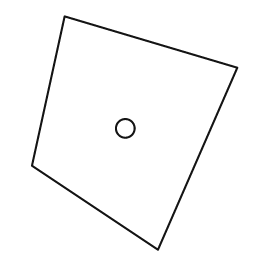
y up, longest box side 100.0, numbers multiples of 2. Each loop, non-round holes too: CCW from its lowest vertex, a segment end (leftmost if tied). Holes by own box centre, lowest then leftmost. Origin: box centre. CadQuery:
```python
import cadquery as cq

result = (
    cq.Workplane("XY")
    .moveTo(10.0, -50.0)
    .lineTo(44.0, 28.0)
    .lineTo(-30.0, 50.0)
    .lineTo(-44.0, -14.0)
    .close()
    .moveTo(-4.0, 2.0)
    .circle(4.0)
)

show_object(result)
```